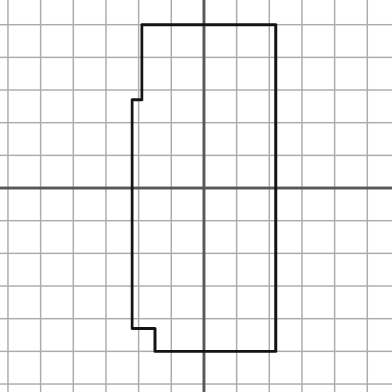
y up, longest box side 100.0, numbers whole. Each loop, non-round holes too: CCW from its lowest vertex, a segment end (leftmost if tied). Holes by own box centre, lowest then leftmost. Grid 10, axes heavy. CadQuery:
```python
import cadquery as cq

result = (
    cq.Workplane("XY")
    .moveTo(-15.0, -50.0)
    .lineTo(22.0, -50.0)
    .lineTo(22.0, 50.0)
    .lineTo(-19.0, 50.0)
    .lineTo(-19.0, 27.0)
    .lineTo(-22.0, 27.0)
    .lineTo(-22.0, -43.0)
    .lineTo(-15.0, -43.0)
    .close()
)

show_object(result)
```